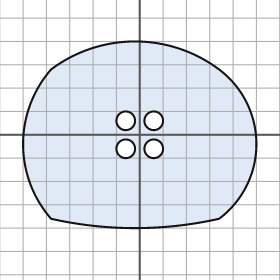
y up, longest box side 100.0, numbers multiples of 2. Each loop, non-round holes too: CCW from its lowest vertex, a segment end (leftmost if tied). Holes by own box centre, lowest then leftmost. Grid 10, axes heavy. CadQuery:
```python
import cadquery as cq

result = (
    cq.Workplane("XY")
    .moveTo(-38.0, -36.0)
    .threePointArc((-2.0, -40.0), (34.0, -36.0))
    .threePointArc((50.0, -4.0), (34.0, 28.0))
    .threePointArc((-2.0, 40.0), (-38.0, 28.0))
    .threePointArc((-50.0, -4.0), (-38.0, -36.0))
    .close()
    .moveTo(-6.0, -6.0)
    .circle(4.0)
    .moveTo(6.0, -6.0)
    .circle(4.0)
    .moveTo(-6.0, 6.0)
    .circle(4.0)
    .moveTo(6.0, 6.0)
    .circle(4.0)
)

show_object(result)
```